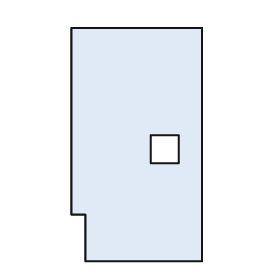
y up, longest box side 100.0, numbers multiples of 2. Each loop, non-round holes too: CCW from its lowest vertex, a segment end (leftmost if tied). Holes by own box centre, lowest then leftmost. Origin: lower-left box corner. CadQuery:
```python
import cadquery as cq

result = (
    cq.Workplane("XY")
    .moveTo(6.0, 0.0)
    .lineTo(56.0, 0.0)
    .lineTo(56.0, 100.0)
    .lineTo(0.0, 100.0)
    .lineTo(0.0, 20.0)
    .lineTo(6.0, 20.0)
    .close()
    .moveTo(34.0, 42.0)
    .lineTo(46.0, 42.0)
    .lineTo(46.0, 54.0)
    .lineTo(34.0, 54.0)
    .close()
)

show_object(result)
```